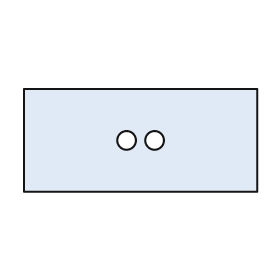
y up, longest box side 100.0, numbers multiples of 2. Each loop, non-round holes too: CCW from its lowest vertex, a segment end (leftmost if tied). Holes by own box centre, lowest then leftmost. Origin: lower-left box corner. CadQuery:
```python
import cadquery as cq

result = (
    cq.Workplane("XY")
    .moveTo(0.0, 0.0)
    .lineTo(100.0, 0.0)
    .lineTo(100.0, 44.0)
    .lineTo(0.0, 44.0)
    .close()
    .moveTo(44.0, 22.0)
    .circle(4.0)
    .moveTo(56.0, 22.0)
    .circle(4.0)
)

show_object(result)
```